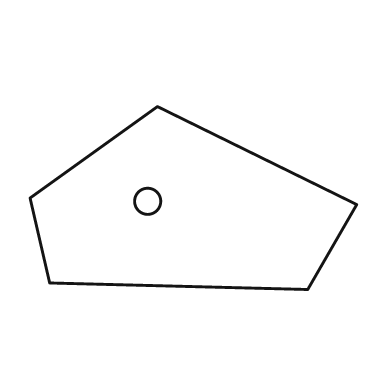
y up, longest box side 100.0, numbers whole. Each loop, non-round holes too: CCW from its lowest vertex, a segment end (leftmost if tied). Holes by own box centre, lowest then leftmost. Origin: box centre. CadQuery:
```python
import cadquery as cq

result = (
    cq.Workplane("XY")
    .moveTo(35.0, -28.0)
    .lineTo(50.0, -2.0)
    .lineTo(-11.0, 28.0)
    .lineTo(-50.0, 0.0)
    .lineTo(-44.0, -26.0)
    .close()
    .moveTo(-14.0, -1.0)
    .circle(4.0)
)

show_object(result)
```